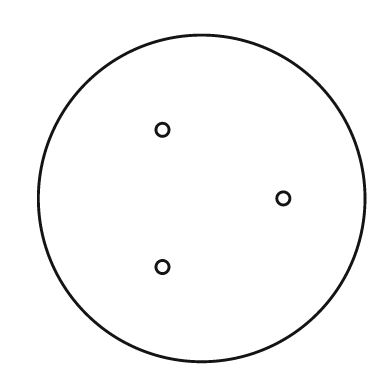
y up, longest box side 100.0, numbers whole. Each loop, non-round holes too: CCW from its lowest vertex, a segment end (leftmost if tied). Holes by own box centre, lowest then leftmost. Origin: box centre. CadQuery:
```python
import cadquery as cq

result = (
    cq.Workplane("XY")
    .moveTo(0.0, 0.0)
    .circle(50.0)
    .moveTo(-12.0, -21.0)
    .circle(2.0)
    .moveTo(25.0, 0.0)
    .circle(2.0)
    .moveTo(-12.0, 21.0)
    .circle(2.0)
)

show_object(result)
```